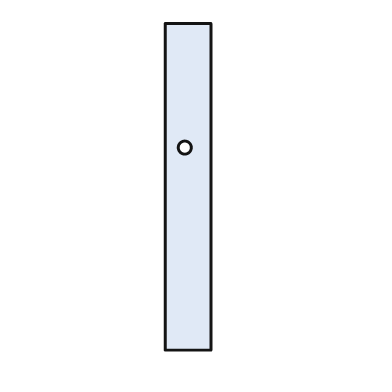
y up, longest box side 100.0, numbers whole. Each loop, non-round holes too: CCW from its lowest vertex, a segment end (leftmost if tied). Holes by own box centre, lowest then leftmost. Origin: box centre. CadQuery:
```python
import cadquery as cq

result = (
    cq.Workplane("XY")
    .moveTo(-7.0, -50.0)
    .lineTo(7.0, -50.0)
    .lineTo(7.0, 50.0)
    .lineTo(-7.0, 50.0)
    .close()
    .moveTo(-1.0, 12.0)
    .circle(2.0)
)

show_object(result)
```